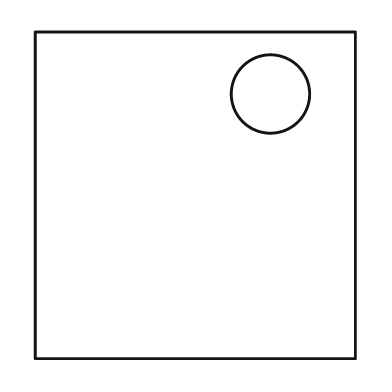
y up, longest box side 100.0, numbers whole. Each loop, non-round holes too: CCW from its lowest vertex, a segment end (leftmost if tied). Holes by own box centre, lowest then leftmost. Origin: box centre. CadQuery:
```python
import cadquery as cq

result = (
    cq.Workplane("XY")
    .moveTo(-49.0, -50.0)
    .lineTo(49.0, -50.0)
    .lineTo(49.0, 50.0)
    .lineTo(-49.0, 50.0)
    .close()
    .moveTo(23.0, 31.0)
    .circle(12.0)
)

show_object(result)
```